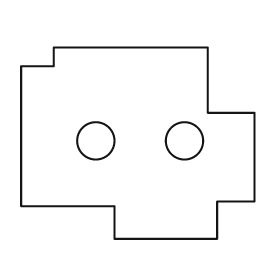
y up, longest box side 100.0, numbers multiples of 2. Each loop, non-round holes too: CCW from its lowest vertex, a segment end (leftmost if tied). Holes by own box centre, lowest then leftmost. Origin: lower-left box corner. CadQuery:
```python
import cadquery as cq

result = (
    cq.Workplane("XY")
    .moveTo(40.0, 0.0)
    .lineTo(84.0, 0.0)
    .lineTo(84.0, 16.0)
    .lineTo(100.0, 16.0)
    .lineTo(100.0, 54.0)
    .lineTo(80.0, 54.0)
    .lineTo(80.0, 82.0)
    .lineTo(14.0, 82.0)
    .lineTo(14.0, 74.0)
    .lineTo(0.0, 74.0)
    .lineTo(0.0, 14.0)
    .lineTo(40.0, 14.0)
    .close()
    .moveTo(32.0, 42.0)
    .circle(8.0)
    .moveTo(70.0, 42.0)
    .circle(8.0)
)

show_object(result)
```